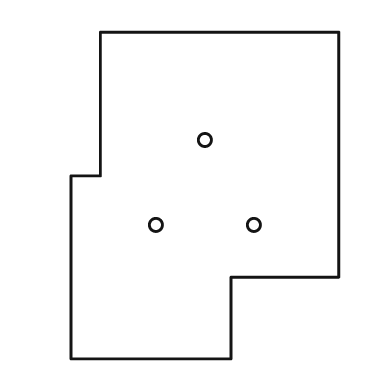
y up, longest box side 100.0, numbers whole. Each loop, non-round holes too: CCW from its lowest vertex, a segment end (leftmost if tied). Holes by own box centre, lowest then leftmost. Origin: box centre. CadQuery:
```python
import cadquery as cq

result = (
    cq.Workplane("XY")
    .moveTo(-41.0, -50.0)
    .lineTo(8.0, -50.0)
    .lineTo(8.0, -25.0)
    .lineTo(41.0, -25.0)
    .lineTo(41.0, 50.0)
    .lineTo(-32.0, 50.0)
    .lineTo(-32.0, 6.0)
    .lineTo(-41.0, 6.0)
    .close()
    .moveTo(-15.0, -9.0)
    .circle(2.0)
    .moveTo(15.0, -9.0)
    .circle(2.0)
    .moveTo(0.0, 17.0)
    .circle(2.0)
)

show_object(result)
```